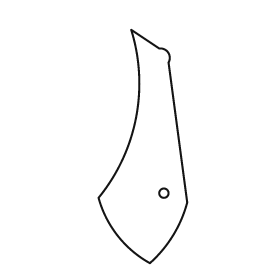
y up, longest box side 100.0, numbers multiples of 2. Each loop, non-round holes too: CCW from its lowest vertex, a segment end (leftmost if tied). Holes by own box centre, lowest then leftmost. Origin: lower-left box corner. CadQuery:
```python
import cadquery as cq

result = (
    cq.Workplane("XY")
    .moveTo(22.0, 0.0)
    .threePointArc((32.0, 12.0), (38.0, 26.0))
    .lineTo(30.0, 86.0)
    .threePointArc((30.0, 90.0), (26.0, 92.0))
    .lineTo(14.0, 100.0)
    .threePointArc((16.0, 62.0), (0.0, 28.0))
    .threePointArc((8.0, 12.0), (22.0, 0.0))
    .close()
    .moveTo(28.0, 30.0)
    .circle(2.0)
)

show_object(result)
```